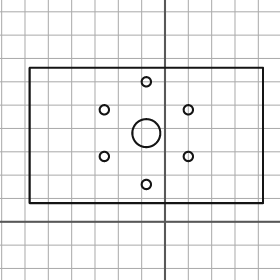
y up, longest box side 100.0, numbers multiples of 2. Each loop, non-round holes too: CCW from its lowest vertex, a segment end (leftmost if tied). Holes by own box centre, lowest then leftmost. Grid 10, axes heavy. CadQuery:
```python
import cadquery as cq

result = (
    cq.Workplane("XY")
    .moveTo(-58.0, 8.0)
    .lineTo(42.0, 8.0)
    .lineTo(42.0, 66.0)
    .lineTo(-58.0, 66.0)
    .close()
    .moveTo(-8.0, 16.0)
    .circle(2.0)
    .moveTo(-26.0, 28.0)
    .circle(2.0)
    .moveTo(10.0, 28.0)
    .circle(2.0)
    .moveTo(-8.0, 38.0)
    .circle(6.0)
    .moveTo(-26.0, 48.0)
    .circle(2.0)
    .moveTo(10.0, 48.0)
    .circle(2.0)
    .moveTo(-8.0, 60.0)
    .circle(2.0)
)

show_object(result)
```